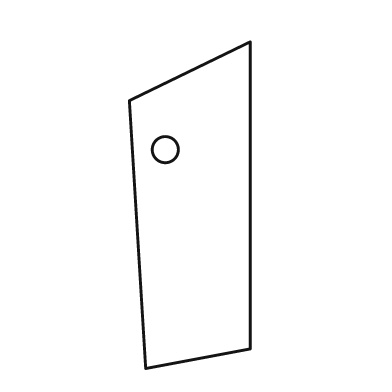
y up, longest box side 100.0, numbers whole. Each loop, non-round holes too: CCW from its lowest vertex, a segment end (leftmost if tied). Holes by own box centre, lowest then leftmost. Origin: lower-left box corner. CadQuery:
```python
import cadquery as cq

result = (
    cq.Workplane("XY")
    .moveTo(5.0, 0.0)
    .lineTo(37.0, 6.0)
    .lineTo(37.0, 100.0)
    .lineTo(0.0, 82.0)
    .close()
    .moveTo(11.0, 67.0)
    .circle(4.0)
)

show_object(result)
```